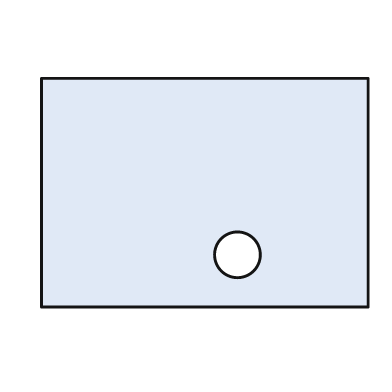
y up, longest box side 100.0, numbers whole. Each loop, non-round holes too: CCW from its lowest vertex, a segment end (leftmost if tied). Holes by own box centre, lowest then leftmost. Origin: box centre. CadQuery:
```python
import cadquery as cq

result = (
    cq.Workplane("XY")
    .moveTo(-50.0, -35.0)
    .lineTo(50.0, -35.0)
    .lineTo(50.0, 35.0)
    .lineTo(-50.0, 35.0)
    .close()
    .moveTo(10.0, -19.0)
    .circle(7.0)
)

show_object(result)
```